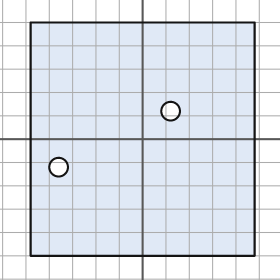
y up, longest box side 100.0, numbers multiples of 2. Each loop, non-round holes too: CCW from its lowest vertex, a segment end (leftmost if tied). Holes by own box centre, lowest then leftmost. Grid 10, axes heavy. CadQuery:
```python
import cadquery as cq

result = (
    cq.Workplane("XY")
    .moveTo(-48.0, -50.0)
    .lineTo(48.0, -50.0)
    .lineTo(48.0, 50.0)
    .lineTo(-48.0, 50.0)
    .close()
    .moveTo(-36.0, -12.0)
    .circle(4.0)
    .moveTo(12.0, 12.0)
    .circle(4.0)
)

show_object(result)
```